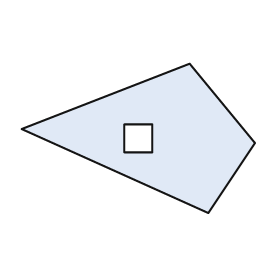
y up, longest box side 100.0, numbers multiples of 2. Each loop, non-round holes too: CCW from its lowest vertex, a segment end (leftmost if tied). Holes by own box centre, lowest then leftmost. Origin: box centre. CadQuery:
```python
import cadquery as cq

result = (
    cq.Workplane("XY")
    .moveTo(30.0, -32.0)
    .lineTo(50.0, -2.0)
    .lineTo(22.0, 32.0)
    .lineTo(-50.0, 4.0)
    .close()
    .moveTo(-6.0, -6.0)
    .lineTo(6.0, -6.0)
    .lineTo(6.0, 6.0)
    .lineTo(-6.0, 6.0)
    .close()
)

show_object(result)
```